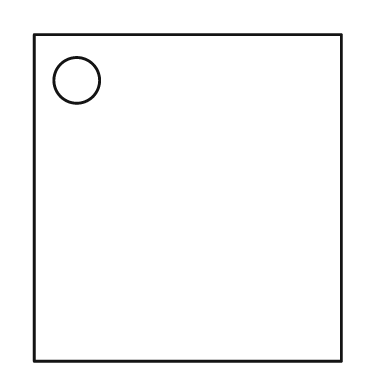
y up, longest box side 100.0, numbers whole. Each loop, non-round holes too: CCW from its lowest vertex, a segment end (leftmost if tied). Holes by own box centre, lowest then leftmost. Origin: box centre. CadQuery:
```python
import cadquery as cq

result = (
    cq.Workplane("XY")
    .moveTo(-47.0, -50.0)
    .lineTo(47.0, -50.0)
    .lineTo(47.0, 50.0)
    .lineTo(-47.0, 50.0)
    .close()
    .moveTo(-34.0, 36.0)
    .circle(7.0)
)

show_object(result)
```